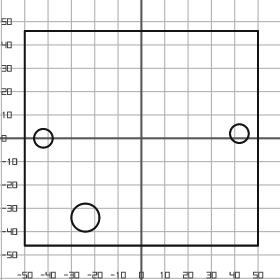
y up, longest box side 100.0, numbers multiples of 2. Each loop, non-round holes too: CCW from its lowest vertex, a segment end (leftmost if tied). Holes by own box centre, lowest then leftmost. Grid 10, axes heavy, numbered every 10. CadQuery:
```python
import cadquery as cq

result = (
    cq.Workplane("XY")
    .moveTo(-50.0, -46.0)
    .lineTo(50.0, -46.0)
    .lineTo(50.0, 46.0)
    .lineTo(-50.0, 46.0)
    .close()
    .moveTo(-24.0, -34.0)
    .circle(6.0)
    .moveTo(-42.0, 0.0)
    .circle(4.0)
    .moveTo(42.0, 2.0)
    .circle(4.0)
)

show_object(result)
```